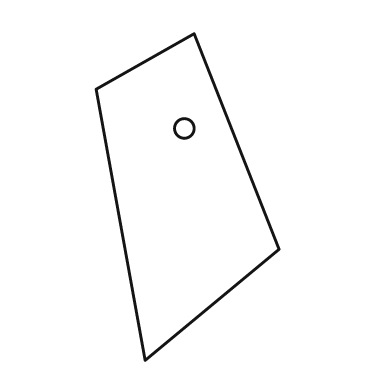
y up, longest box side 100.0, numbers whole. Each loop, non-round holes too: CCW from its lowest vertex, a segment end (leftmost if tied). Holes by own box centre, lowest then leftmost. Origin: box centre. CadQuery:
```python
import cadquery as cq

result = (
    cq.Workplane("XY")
    .moveTo(-13.0, -50.0)
    .lineTo(28.0, -16.0)
    .lineTo(2.0, 50.0)
    .lineTo(-28.0, 33.0)
    .close()
    .moveTo(-1.0, 21.0)
    .circle(3.0)
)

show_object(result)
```